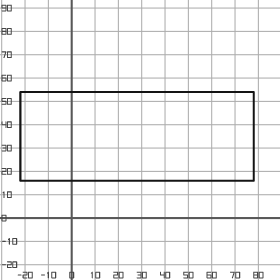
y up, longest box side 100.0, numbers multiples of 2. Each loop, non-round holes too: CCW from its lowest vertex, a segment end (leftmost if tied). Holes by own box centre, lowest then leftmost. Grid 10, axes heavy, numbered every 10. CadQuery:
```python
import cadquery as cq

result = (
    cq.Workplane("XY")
    .moveTo(-22.0, 16.0)
    .lineTo(78.0, 16.0)
    .lineTo(78.0, 54.0)
    .lineTo(-22.0, 54.0)
    .close()
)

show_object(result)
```